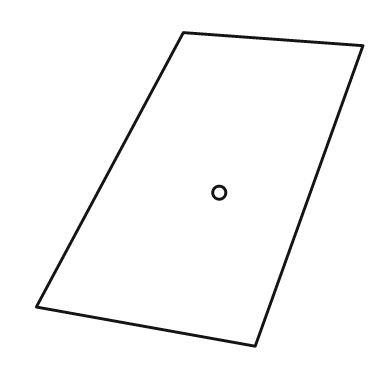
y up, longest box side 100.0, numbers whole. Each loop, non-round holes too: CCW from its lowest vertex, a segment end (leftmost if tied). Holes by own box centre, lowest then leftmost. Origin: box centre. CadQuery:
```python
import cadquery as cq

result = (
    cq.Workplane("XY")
    .moveTo(17.0, -48.0)
    .lineTo(50.0, 44.0)
    .lineTo(-5.0, 48.0)
    .lineTo(-50.0, -36.0)
    .close()
    .moveTo(6.0, -1.0)
    .circle(2.0)
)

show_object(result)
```